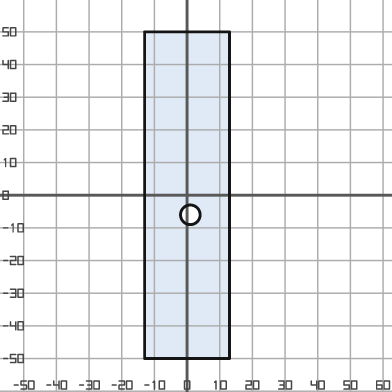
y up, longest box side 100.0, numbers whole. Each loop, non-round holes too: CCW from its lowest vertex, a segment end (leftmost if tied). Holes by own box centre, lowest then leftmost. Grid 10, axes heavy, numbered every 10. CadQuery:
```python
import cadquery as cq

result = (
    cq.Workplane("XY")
    .moveTo(-13.0, -50.0)
    .lineTo(13.0, -50.0)
    .lineTo(13.0, 50.0)
    .lineTo(-13.0, 50.0)
    .close()
    .moveTo(1.0, -6.0)
    .circle(3.0)
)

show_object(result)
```